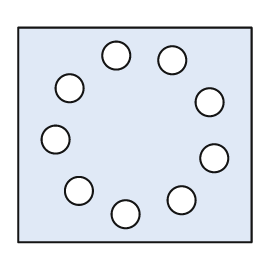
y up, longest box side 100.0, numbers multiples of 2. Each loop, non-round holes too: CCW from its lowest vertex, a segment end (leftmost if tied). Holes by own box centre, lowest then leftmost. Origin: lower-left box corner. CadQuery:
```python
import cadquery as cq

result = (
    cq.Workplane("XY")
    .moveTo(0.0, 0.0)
    .lineTo(100.0, 0.0)
    .lineTo(100.0, 92.0)
    .lineTo(0.0, 92.0)
    .close()
    .moveTo(46.0, 12.0)
    .circle(6.0)
    .moveTo(70.0, 18.0)
    .circle(6.0)
    .moveTo(26.0, 22.0)
    .circle(6.0)
    .moveTo(84.0, 36.0)
    .circle(6.0)
    .moveTo(16.0, 44.0)
    .circle(6.0)
    .moveTo(82.0, 60.0)
    .circle(6.0)
    .moveTo(22.0, 66.0)
    .circle(6.0)
    .moveTo(66.0, 78.0)
    .circle(6.0)
    .moveTo(42.0, 80.0)
    .circle(6.0)
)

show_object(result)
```